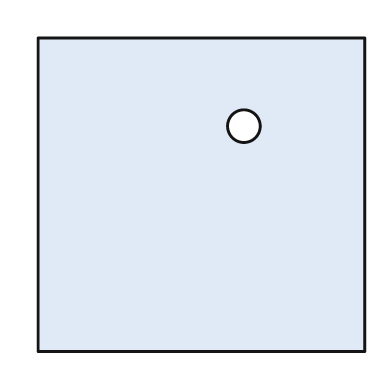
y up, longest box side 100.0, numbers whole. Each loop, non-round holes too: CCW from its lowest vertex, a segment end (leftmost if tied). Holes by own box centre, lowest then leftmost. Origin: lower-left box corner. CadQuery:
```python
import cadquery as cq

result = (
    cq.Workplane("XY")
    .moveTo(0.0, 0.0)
    .lineTo(100.0, 0.0)
    .lineTo(100.0, 96.0)
    .lineTo(0.0, 96.0)
    .close()
    .moveTo(63.0, 69.0)
    .circle(5.0)
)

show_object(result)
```